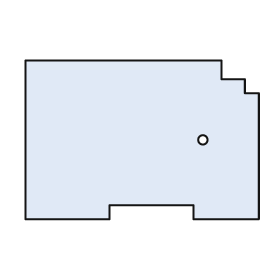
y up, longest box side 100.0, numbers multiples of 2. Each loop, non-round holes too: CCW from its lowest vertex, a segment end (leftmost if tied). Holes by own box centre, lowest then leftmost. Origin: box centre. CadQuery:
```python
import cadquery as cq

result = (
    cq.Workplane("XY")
    .moveTo(-50.0, -34.0)
    .lineTo(-14.0, -34.0)
    .lineTo(-14.0, -28.0)
    .lineTo(22.0, -28.0)
    .lineTo(22.0, -34.0)
    .lineTo(50.0, -34.0)
    .lineTo(50.0, 20.0)
    .lineTo(44.0, 20.0)
    .lineTo(44.0, 26.0)
    .lineTo(34.0, 26.0)
    .lineTo(34.0, 34.0)
    .lineTo(-50.0, 34.0)
    .close()
    .moveTo(26.0, 0.0)
    .circle(2.0)
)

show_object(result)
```